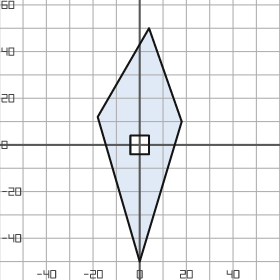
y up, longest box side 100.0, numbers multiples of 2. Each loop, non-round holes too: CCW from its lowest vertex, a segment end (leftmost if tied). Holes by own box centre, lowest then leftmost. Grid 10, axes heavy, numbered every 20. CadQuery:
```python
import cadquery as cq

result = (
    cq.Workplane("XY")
    .moveTo(0.0, -50.0)
    .lineTo(18.0, 10.0)
    .lineTo(4.0, 50.0)
    .lineTo(-18.0, 12.0)
    .close()
    .moveTo(-4.0, -4.0)
    .lineTo(4.0, -4.0)
    .lineTo(4.0, 4.0)
    .lineTo(-4.0, 4.0)
    .close()
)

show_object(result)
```